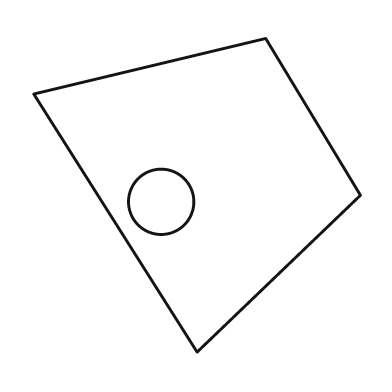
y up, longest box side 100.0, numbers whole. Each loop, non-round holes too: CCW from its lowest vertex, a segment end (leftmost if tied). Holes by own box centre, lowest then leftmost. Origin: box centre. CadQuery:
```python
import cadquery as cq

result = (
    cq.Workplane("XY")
    .moveTo(0.0, -48.0)
    .lineTo(50.0, 0.0)
    .lineTo(21.0, 48.0)
    .lineTo(-50.0, 31.0)
    .close()
    .moveTo(-11.0, -2.0)
    .circle(10.0)
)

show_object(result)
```